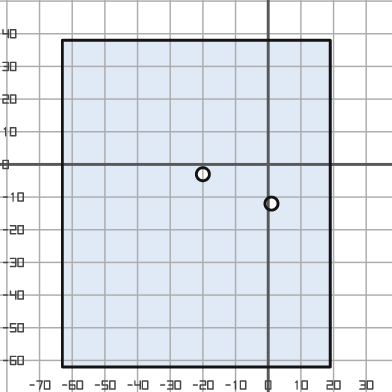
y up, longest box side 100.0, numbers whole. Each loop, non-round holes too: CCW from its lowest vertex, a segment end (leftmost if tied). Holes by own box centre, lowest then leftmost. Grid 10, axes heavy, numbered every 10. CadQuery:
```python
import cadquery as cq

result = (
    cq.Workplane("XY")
    .moveTo(-63.0, -62.0)
    .lineTo(19.0, -62.0)
    .lineTo(19.0, 38.0)
    .lineTo(-63.0, 38.0)
    .close()
    .moveTo(1.0, -12.0)
    .circle(2.0)
    .moveTo(-20.0, -3.0)
    .circle(2.0)
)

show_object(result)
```